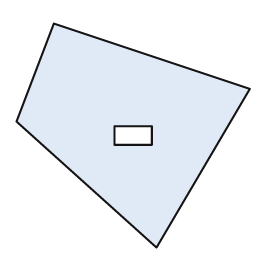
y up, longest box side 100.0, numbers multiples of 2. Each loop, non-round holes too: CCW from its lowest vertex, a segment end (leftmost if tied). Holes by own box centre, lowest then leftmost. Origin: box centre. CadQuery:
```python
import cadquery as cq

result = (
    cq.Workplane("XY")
    .moveTo(10.0, -48.0)
    .lineTo(50.0, 20.0)
    .lineTo(-34.0, 48.0)
    .lineTo(-50.0, 6.0)
    .close()
    .moveTo(-8.0, -4.0)
    .lineTo(8.0, -4.0)
    .lineTo(8.0, 4.0)
    .lineTo(-8.0, 4.0)
    .close()
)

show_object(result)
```